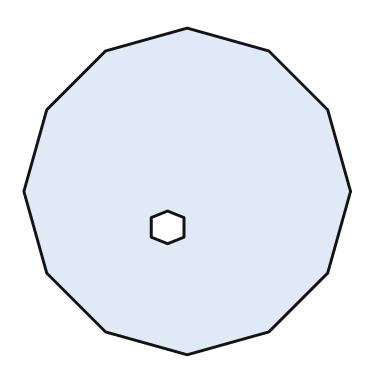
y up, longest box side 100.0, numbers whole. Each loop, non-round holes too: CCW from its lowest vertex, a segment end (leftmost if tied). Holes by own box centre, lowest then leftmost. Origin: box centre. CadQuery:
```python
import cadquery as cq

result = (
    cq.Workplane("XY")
    .moveTo(0.0, -50.0)
    .lineTo(25.0, -43.0)
    .lineTo(43.0, -25.0)
    .lineTo(50.0, 0.0)
    .lineTo(43.0, 25.0)
    .lineTo(25.0, 43.0)
    .lineTo(0.0, 50.0)
    .lineTo(-25.0, 43.0)
    .lineTo(-43.0, 25.0)
    .lineTo(-50.0, 0.0)
    .lineTo(-43.0, -25.0)
    .lineTo(-25.0, -43.0)
    .close()
    .moveTo(-6.0, -16.0)
    .lineTo(-1.0, -14.0)
    .lineTo(-1.0, -8.0)
    .lineTo(-6.0, -6.0)
    .lineTo(-11.0, -8.0)
    .lineTo(-11.0, -14.0)
    .close()
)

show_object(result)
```